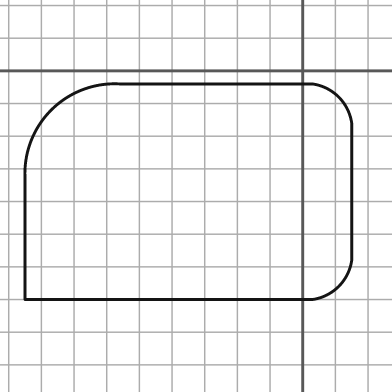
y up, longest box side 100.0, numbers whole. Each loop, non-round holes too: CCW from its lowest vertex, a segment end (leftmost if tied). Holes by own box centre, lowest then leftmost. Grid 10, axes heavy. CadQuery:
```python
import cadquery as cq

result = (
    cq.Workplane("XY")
    .moveTo(-85.0, -70.0)
    .lineTo(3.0, -70.0)
    .threePointArc((11.0, -66.0), (15.0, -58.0))
    .lineTo(15.0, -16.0)
    .threePointArc((11.0, -8.0), (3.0, -4.0))
    .lineTo(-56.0, -4.0)
    .threePointArc((-77.0, -12.0), (-85.0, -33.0))
    .close()
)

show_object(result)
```